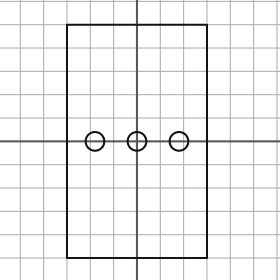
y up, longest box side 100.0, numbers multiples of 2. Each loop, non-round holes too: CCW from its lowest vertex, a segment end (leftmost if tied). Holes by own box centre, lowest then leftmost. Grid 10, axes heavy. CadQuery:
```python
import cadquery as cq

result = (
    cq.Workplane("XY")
    .moveTo(-30.0, -50.0)
    .lineTo(30.0, -50.0)
    .lineTo(30.0, 50.0)
    .lineTo(-30.0, 50.0)
    .close()
    .moveTo(-18.0, 0.0)
    .circle(4.0)
    .moveTo(0.0, 0.0)
    .circle(4.0)
    .moveTo(18.0, 0.0)
    .circle(4.0)
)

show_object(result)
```